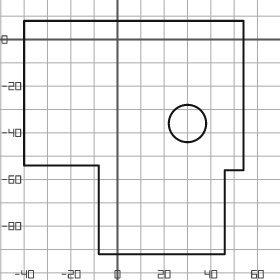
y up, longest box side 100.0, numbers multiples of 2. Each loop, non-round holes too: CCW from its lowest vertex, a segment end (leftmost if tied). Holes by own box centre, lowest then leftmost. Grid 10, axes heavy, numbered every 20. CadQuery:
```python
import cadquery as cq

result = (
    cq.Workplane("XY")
    .moveTo(-8.0, -92.0)
    .lineTo(46.0, -92.0)
    .lineTo(46.0, -56.0)
    .lineTo(54.0, -56.0)
    .lineTo(54.0, 8.0)
    .lineTo(-40.0, 8.0)
    .lineTo(-40.0, -54.0)
    .lineTo(-8.0, -54.0)
    .close()
    .moveTo(30.0, -36.0)
    .circle(8.0)
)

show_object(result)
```